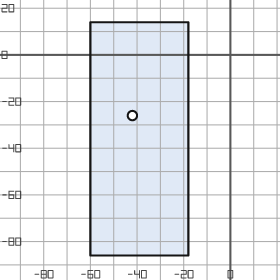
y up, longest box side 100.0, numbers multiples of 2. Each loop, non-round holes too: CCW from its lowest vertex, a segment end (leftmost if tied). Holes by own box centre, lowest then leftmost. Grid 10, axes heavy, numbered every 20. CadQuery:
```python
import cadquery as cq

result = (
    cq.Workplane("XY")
    .moveTo(-60.0, -86.0)
    .lineTo(-18.0, -86.0)
    .lineTo(-18.0, 14.0)
    .lineTo(-60.0, 14.0)
    .close()
    .moveTo(-42.0, -26.0)
    .circle(2.0)
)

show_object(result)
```